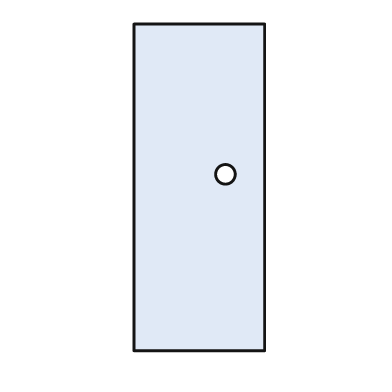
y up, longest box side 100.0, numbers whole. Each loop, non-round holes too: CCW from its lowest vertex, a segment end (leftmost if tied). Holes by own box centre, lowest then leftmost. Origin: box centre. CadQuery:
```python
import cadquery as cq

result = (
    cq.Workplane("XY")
    .moveTo(-20.0, -50.0)
    .lineTo(20.0, -50.0)
    .lineTo(20.0, 50.0)
    .lineTo(-20.0, 50.0)
    .close()
    .moveTo(8.0, 4.0)
    .circle(3.0)
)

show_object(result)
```